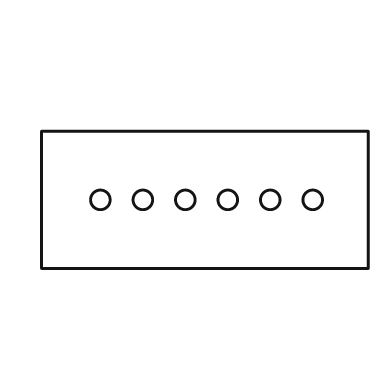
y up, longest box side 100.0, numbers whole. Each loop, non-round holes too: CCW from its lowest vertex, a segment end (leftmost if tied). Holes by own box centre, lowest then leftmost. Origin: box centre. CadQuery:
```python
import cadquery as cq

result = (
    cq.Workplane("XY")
    .moveTo(-50.0, -21.0)
    .lineTo(50.0, -21.0)
    .lineTo(50.0, 21.0)
    .lineTo(-50.0, 21.0)
    .close()
    .moveTo(-32.0, 0.0)
    .circle(3.0)
    .moveTo(-19.0, 0.0)
    .circle(3.0)
    .moveTo(-6.0, 0.0)
    .circle(3.0)
    .moveTo(7.0, 0.0)
    .circle(3.0)
    .moveTo(20.0, 0.0)
    .circle(3.0)
    .moveTo(33.0, 0.0)
    .circle(3.0)
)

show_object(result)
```